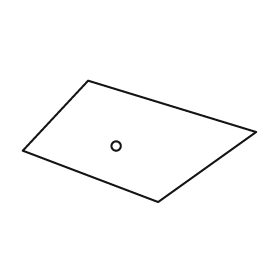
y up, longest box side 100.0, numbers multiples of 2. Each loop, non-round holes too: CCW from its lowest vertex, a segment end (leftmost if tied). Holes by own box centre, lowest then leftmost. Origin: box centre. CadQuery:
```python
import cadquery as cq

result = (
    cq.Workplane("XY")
    .moveTo(8.0, -26.0)
    .lineTo(50.0, 4.0)
    .lineTo(-22.0, 26.0)
    .lineTo(-50.0, -4.0)
    .close()
    .moveTo(-10.0, -2.0)
    .circle(2.0)
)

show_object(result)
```